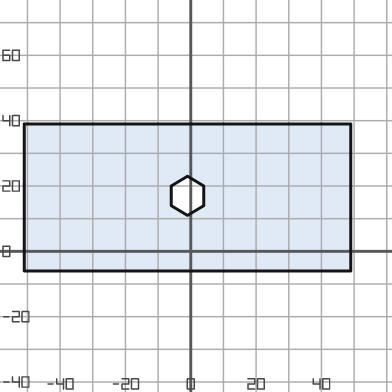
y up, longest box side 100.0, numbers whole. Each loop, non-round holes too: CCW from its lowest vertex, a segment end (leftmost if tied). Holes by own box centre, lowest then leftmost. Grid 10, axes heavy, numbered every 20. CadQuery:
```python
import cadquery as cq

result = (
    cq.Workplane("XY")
    .moveTo(-51.0, -6.0)
    .lineTo(49.0, -6.0)
    .lineTo(49.0, 39.0)
    .lineTo(-51.0, 39.0)
    .close()
    .moveTo(-1.0, 11.0)
    .lineTo(4.0, 14.0)
    .lineTo(4.0, 20.0)
    .lineTo(-1.0, 23.0)
    .lineTo(-6.0, 20.0)
    .lineTo(-6.0, 14.0)
    .close()
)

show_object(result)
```